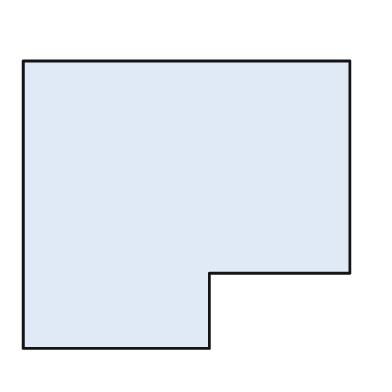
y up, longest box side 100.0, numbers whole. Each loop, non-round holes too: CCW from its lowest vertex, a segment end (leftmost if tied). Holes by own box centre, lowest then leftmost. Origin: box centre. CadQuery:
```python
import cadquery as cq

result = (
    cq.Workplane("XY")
    .moveTo(-50.0, -44.0)
    .lineTo(7.0, -44.0)
    .lineTo(7.0, -21.0)
    .lineTo(50.0, -21.0)
    .lineTo(50.0, 44.0)
    .lineTo(-50.0, 44.0)
    .close()
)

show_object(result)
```